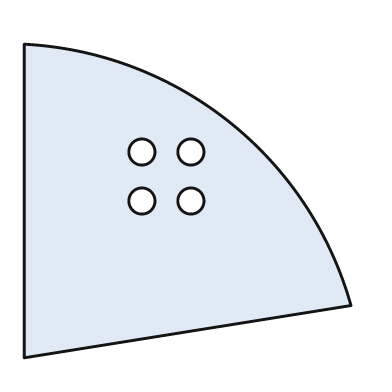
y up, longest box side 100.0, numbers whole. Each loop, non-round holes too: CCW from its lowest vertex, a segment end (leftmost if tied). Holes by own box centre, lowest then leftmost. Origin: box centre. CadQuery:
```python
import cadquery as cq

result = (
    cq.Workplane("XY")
    .moveTo(-50.0, -48.0)
    .lineTo(50.0, -32.0)
    .threePointArc((13.0, 24.0), (-50.0, 48.0))
    .close()
    .moveTo(-14.0, 0.0)
    .circle(4.0)
    .moveTo(1.0, 0.0)
    .circle(4.0)
    .moveTo(-14.0, 15.0)
    .circle(4.0)
    .moveTo(1.0, 15.0)
    .circle(4.0)
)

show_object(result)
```